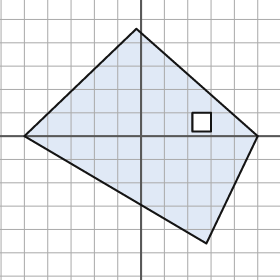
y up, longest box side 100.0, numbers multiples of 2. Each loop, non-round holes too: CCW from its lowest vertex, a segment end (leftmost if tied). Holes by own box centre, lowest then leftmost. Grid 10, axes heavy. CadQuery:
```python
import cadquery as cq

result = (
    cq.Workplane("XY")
    .moveTo(28.0, -46.0)
    .lineTo(50.0, 0.0)
    .lineTo(-2.0, 46.0)
    .lineTo(-50.0, 0.0)
    .close()
    .moveTo(22.0, 2.0)
    .lineTo(30.0, 2.0)
    .lineTo(30.0, 10.0)
    .lineTo(22.0, 10.0)
    .close()
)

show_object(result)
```